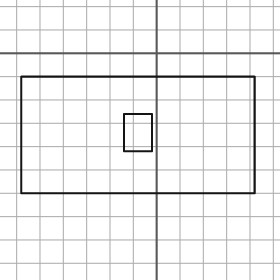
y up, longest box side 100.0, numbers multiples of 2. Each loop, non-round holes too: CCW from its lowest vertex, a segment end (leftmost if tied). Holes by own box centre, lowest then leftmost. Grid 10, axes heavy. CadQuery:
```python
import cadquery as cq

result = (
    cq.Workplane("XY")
    .moveTo(-58.0, -60.0)
    .lineTo(42.0, -60.0)
    .lineTo(42.0, -10.0)
    .lineTo(-58.0, -10.0)
    .close()
    .moveTo(-14.0, -42.0)
    .lineTo(-2.0, -42.0)
    .lineTo(-2.0, -26.0)
    .lineTo(-14.0, -26.0)
    .close()
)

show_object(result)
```